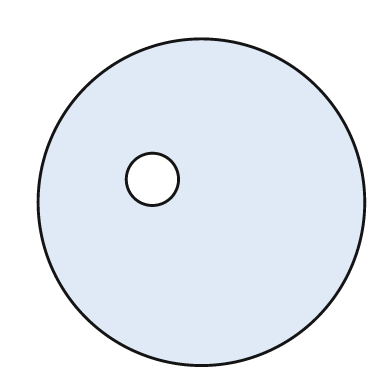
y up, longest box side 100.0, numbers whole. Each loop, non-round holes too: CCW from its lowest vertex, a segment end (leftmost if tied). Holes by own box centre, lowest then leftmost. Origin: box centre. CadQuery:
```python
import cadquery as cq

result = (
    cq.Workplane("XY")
    .moveTo(0.0, 0.0)
    .circle(50.0)
    .moveTo(-15.0, 7.0)
    .circle(8.0)
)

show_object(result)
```